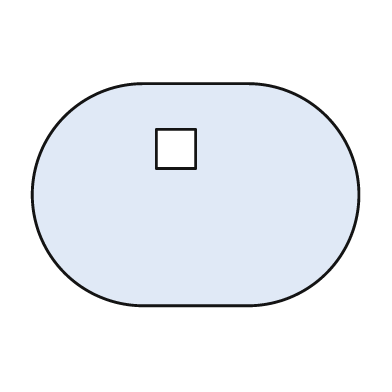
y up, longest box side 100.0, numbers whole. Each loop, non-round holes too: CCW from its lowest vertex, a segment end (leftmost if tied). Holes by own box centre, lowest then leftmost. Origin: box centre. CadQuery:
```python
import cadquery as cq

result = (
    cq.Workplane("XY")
    .moveTo(-16.0, -34.0)
    .lineTo(16.0, -34.0)
    .threePointArc((50.0, 0.0), (16.0, 34.0))
    .lineTo(-16.0, 34.0)
    .threePointArc((-50.0, 0.0), (-16.0, -34.0))
    .close()
    .moveTo(-12.0, 8.0)
    .lineTo(0.0, 8.0)
    .lineTo(0.0, 20.0)
    .lineTo(-12.0, 20.0)
    .close()
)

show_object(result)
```